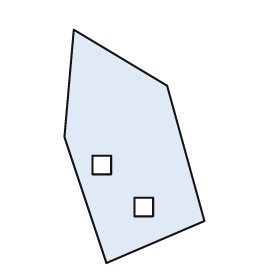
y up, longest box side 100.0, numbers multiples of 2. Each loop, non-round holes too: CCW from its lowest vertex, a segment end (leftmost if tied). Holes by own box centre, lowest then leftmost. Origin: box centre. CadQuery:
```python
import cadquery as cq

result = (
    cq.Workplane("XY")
    .moveTo(-12.0, -50.0)
    .lineTo(30.0, -32.0)
    .lineTo(14.0, 26.0)
    .lineTo(-26.0, 50.0)
    .lineTo(-30.0, 4.0)
    .close()
    .moveTo(0.0, -30.0)
    .lineTo(8.0, -30.0)
    .lineTo(8.0, -22.0)
    .lineTo(0.0, -22.0)
    .close()
    .moveTo(-18.0, -12.0)
    .lineTo(-10.0, -12.0)
    .lineTo(-10.0, -4.0)
    .lineTo(-18.0, -4.0)
    .close()
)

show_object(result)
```